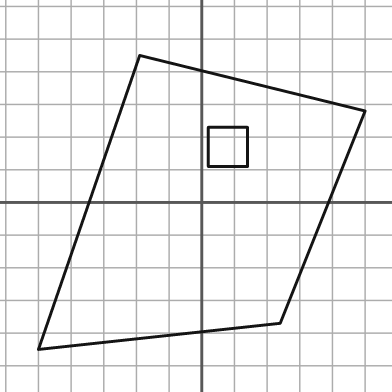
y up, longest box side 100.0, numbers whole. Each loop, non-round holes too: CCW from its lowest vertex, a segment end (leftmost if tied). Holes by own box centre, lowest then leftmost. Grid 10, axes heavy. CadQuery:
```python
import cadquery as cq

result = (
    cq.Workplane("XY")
    .moveTo(-50.0, -45.0)
    .lineTo(24.0, -37.0)
    .lineTo(50.0, 28.0)
    .lineTo(-19.0, 45.0)
    .close()
    .moveTo(2.0, 11.0)
    .lineTo(14.0, 11.0)
    .lineTo(14.0, 23.0)
    .lineTo(2.0, 23.0)
    .close()
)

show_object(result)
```